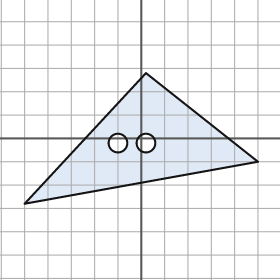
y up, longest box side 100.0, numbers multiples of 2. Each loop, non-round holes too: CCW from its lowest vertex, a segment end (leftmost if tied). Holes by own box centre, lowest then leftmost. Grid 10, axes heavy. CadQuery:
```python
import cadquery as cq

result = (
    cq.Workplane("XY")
    .moveTo(-50.0, -28.0)
    .lineTo(50.0, -10.0)
    .lineTo(2.0, 28.0)
    .close()
    .moveTo(-10.0, -2.0)
    .circle(4.0)
    .moveTo(2.0, -2.0)
    .circle(4.0)
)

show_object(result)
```